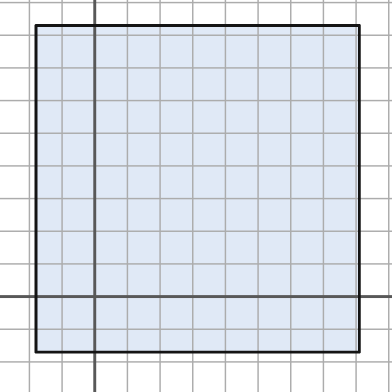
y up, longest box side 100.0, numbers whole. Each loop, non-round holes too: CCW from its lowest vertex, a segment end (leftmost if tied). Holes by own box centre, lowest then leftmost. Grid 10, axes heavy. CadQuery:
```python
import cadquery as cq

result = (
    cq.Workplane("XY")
    .moveTo(-18.0, -17.0)
    .lineTo(81.0, -17.0)
    .lineTo(81.0, 83.0)
    .lineTo(-18.0, 83.0)
    .close()
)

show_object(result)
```